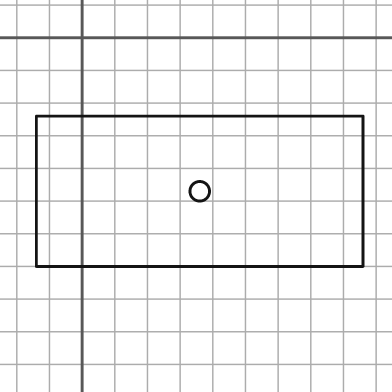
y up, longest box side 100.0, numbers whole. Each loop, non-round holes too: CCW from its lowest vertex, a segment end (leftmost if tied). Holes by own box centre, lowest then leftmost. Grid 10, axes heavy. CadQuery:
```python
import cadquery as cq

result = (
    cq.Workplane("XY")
    .moveTo(-14.0, -70.0)
    .lineTo(86.0, -70.0)
    .lineTo(86.0, -24.0)
    .lineTo(-14.0, -24.0)
    .close()
    .moveTo(36.0, -47.0)
    .circle(3.0)
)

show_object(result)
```